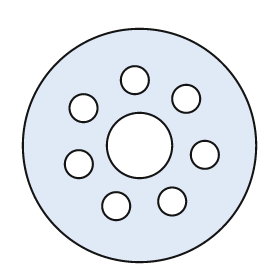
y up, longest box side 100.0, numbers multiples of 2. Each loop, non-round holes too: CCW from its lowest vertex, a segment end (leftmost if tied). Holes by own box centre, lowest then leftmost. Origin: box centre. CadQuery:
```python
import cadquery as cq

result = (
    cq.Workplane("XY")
    .moveTo(0.0, 0.0)
    .circle(50.0)
    .moveTo(-10.0, -26.0)
    .circle(6.0)
    .moveTo(14.0, -24.0)
    .circle(6.0)
    .moveTo(-26.0, -8.0)
    .circle(6.0)
    .moveTo(28.0, -4.0)
    .circle(6.0)
    .moveTo(0.0, 0.0)
    .circle(14.0)
    .moveTo(-24.0, 16.0)
    .circle(6.0)
    .moveTo(20.0, 20.0)
    .circle(6.0)
    .moveTo(-2.0, 28.0)
    .circle(6.0)
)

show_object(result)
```